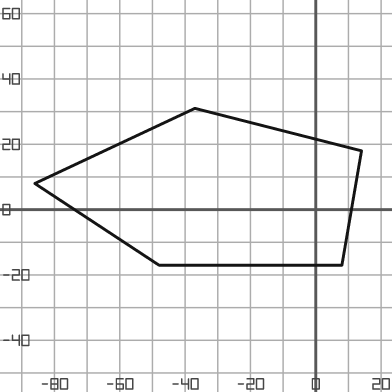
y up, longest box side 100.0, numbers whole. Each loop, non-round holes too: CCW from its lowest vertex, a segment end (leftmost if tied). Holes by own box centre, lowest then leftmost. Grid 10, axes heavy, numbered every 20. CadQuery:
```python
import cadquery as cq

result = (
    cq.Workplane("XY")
    .moveTo(-48.0, -17.0)
    .lineTo(8.0, -17.0)
    .lineTo(14.0, 18.0)
    .lineTo(-37.0, 31.0)
    .lineTo(-86.0, 8.0)
    .close()
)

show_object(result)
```